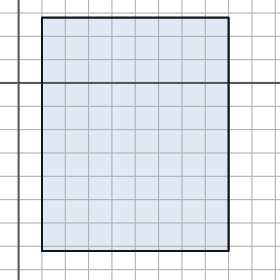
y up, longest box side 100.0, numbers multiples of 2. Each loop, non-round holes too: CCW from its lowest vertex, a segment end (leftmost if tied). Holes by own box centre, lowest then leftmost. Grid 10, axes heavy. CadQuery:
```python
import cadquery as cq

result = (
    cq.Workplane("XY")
    .moveTo(10.0, -72.0)
    .lineTo(90.0, -72.0)
    .lineTo(90.0, 28.0)
    .lineTo(10.0, 28.0)
    .close()
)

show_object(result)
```